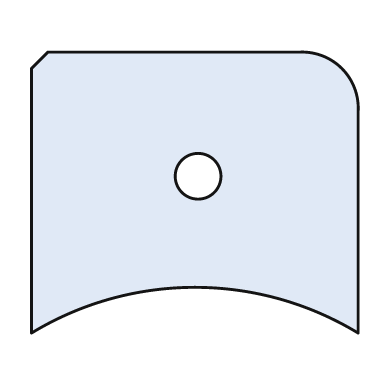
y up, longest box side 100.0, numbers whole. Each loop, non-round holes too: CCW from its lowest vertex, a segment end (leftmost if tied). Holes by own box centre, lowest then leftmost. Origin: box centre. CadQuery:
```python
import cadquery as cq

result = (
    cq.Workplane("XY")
    .moveTo(-50.0, -43.0)
    .threePointArc((0.0, -29.0), (50.0, -43.0))
    .lineTo(50.0, 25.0)
    .threePointArc((45.0, 38.0), (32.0, 43.0))
    .lineTo(-45.0, 43.0)
    .lineTo(-50.0, 38.0)
    .close()
    .moveTo(1.0, 5.0)
    .circle(7.0)
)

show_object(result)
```